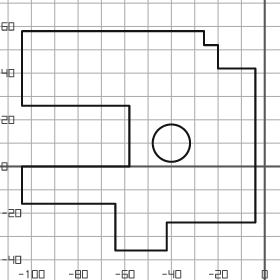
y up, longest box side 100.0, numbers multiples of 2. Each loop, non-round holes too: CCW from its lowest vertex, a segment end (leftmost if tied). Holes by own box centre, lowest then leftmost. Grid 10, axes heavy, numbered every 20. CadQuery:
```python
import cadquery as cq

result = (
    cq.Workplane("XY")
    .moveTo(-64.0, -36.0)
    .lineTo(-42.0, -36.0)
    .lineTo(-42.0, -24.0)
    .lineTo(-4.0, -24.0)
    .lineTo(-4.0, 42.0)
    .lineTo(-20.0, 42.0)
    .lineTo(-20.0, 52.0)
    .lineTo(-26.0, 52.0)
    .lineTo(-26.0, 58.0)
    .lineTo(-104.0, 58.0)
    .lineTo(-104.0, 26.0)
    .lineTo(-58.0, 26.0)
    .lineTo(-58.0, 0.0)
    .lineTo(-104.0, 0.0)
    .lineTo(-104.0, -16.0)
    .lineTo(-64.0, -16.0)
    .close()
    .moveTo(-40.0, 10.0)
    .circle(8.0)
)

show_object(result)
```